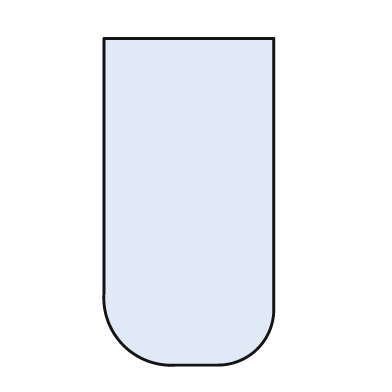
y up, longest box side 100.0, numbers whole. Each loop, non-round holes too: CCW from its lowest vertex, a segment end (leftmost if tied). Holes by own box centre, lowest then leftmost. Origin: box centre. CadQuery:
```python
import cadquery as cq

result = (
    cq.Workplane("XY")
    .moveTo(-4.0, -50.0)
    .lineTo(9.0, -50.0)
    .threePointArc((21.0, -45.0), (26.0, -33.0))
    .lineTo(26.0, 50.0)
    .lineTo(-26.0, 50.0)
    .lineTo(-26.0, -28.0)
    .threePointArc((-20.0, -44.0), (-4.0, -50.0))
    .close()
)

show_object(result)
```